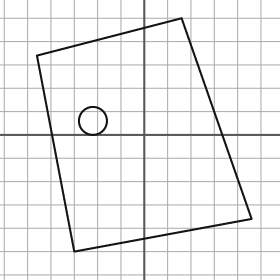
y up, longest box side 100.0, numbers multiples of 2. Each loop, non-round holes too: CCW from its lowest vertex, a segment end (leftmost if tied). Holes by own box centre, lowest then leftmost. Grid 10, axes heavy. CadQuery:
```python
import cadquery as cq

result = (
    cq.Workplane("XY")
    .moveTo(-30.0, -50.0)
    .lineTo(46.0, -36.0)
    .lineTo(16.0, 50.0)
    .lineTo(-46.0, 34.0)
    .close()
    .moveTo(-22.0, 6.0)
    .circle(6.0)
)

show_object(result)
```